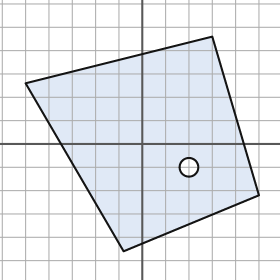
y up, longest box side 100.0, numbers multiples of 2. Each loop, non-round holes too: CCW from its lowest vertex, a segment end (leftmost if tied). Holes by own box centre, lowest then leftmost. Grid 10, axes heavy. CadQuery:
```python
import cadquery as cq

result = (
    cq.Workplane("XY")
    .moveTo(-8.0, -46.0)
    .lineTo(50.0, -22.0)
    .lineTo(30.0, 46.0)
    .lineTo(-50.0, 26.0)
    .close()
    .moveTo(20.0, -10.0)
    .circle(4.0)
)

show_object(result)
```